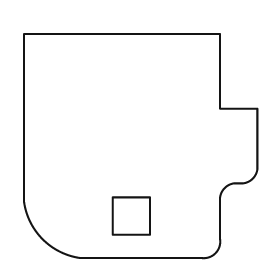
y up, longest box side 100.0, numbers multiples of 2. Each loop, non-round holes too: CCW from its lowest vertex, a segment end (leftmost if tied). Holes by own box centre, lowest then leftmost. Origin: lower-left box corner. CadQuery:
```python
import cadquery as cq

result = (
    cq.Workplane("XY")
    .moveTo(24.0, 0.0)
    .lineTo(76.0, 0.0)
    .threePointArc((82.0, 2.0), (84.0, 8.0))
    .lineTo(84.0, 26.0)
    .threePointArc((86.0, 30.0), (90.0, 32.0))
    .lineTo(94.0, 32.0)
    .threePointArc((98.0, 34.0), (100.0, 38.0))
    .lineTo(100.0, 64.0)
    .lineTo(84.0, 64.0)
    .lineTo(84.0, 96.0)
    .lineTo(0.0, 96.0)
    .lineTo(0.0, 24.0)
    .threePointArc((8.0, 8.0), (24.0, 0.0))
    .close()
    .moveTo(38.0, 10.0)
    .lineTo(54.0, 10.0)
    .lineTo(54.0, 26.0)
    .lineTo(38.0, 26.0)
    .close()
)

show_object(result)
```